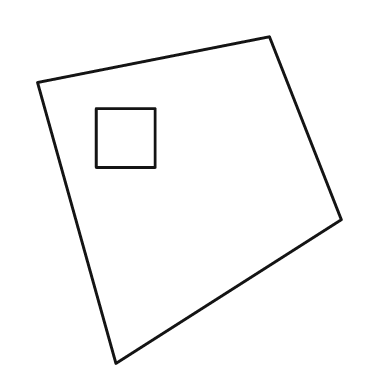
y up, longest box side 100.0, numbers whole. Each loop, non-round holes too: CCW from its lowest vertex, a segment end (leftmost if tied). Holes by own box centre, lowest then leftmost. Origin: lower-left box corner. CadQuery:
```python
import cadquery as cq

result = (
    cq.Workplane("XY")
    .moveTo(24.0, 0.0)
    .lineTo(93.0, 44.0)
    .lineTo(71.0, 100.0)
    .lineTo(0.0, 86.0)
    .close()
    .moveTo(18.0, 60.0)
    .lineTo(36.0, 60.0)
    .lineTo(36.0, 78.0)
    .lineTo(18.0, 78.0)
    .close()
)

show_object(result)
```